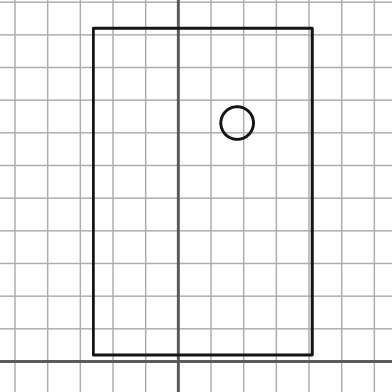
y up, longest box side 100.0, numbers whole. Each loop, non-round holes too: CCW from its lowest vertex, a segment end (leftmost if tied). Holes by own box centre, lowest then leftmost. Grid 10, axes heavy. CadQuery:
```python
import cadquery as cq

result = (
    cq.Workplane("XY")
    .moveTo(-26.0, 2.0)
    .lineTo(41.0, 2.0)
    .lineTo(41.0, 102.0)
    .lineTo(-26.0, 102.0)
    .close()
    .moveTo(18.0, 73.0)
    .circle(5.0)
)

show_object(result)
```